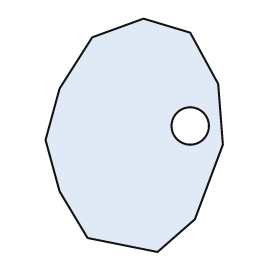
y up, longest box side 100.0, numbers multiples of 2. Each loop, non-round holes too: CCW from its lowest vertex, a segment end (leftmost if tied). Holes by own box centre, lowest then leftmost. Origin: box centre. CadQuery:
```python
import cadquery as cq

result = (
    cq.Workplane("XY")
    .moveTo(10.0, -50.0)
    .lineTo(26.0, -36.0)
    .lineTo(38.0, -4.0)
    .lineTo(36.0, 22.0)
    .lineTo(24.0, 44.0)
    .lineTo(4.0, 50.0)
    .lineTo(-18.0, 42.0)
    .lineTo(-32.0, 20.0)
    .lineTo(-38.0, -2.0)
    .lineTo(-32.0, -24.0)
    .lineTo(-20.0, -44.0)
    .close()
    .moveTo(24.0, 4.0)
    .circle(8.0)
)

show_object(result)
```